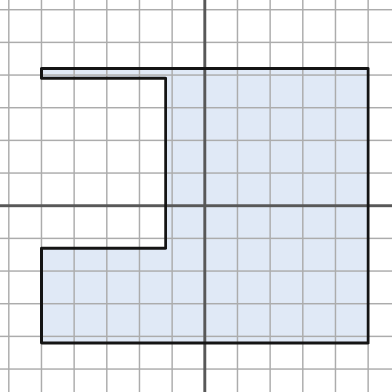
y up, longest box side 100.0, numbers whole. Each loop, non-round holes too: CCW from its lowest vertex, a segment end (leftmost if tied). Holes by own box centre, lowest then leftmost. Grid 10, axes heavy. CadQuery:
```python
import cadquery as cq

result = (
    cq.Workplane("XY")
    .moveTo(-50.0, -42.0)
    .lineTo(50.0, -42.0)
    .lineTo(50.0, 42.0)
    .lineTo(-50.0, 42.0)
    .lineTo(-50.0, 39.0)
    .lineTo(-12.0, 39.0)
    .lineTo(-12.0, -13.0)
    .lineTo(-50.0, -13.0)
    .close()
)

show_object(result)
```